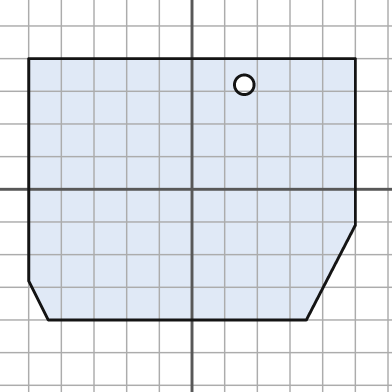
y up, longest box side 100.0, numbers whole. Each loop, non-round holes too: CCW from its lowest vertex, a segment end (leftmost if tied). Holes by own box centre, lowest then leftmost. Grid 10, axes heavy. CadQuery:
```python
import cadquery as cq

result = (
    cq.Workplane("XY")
    .moveTo(-44.0, -40.0)
    .lineTo(35.0, -40.0)
    .lineTo(50.0, -11.0)
    .lineTo(50.0, 40.0)
    .lineTo(-50.0, 40.0)
    .lineTo(-50.0, -28.0)
    .close()
    .moveTo(16.0, 32.0)
    .circle(3.0)
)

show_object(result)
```